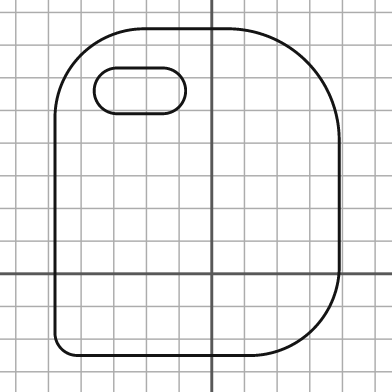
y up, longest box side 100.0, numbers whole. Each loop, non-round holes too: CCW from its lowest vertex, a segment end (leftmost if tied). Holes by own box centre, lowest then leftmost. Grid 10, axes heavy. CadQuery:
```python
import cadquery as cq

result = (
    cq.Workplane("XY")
    .moveTo(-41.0, -25.0)
    .lineTo(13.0, -25.0)
    .threePointArc((31.0, -17.0), (39.0, 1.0))
    .lineTo(39.0, 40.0)
    .threePointArc((29.0, 65.0), (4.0, 75.0))
    .lineTo(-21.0, 75.0)
    .threePointArc((-40.0, 67.0), (-48.0, 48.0))
    .lineTo(-48.0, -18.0)
    .threePointArc((-46.0, -23.0), (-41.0, -25.0))
    .close()
    .moveTo(-29.0, 49.0)
    .lineTo(-15.0, 49.0)
    .threePointArc((-8.0, 56.0), (-15.0, 63.0))
    .lineTo(-29.0, 63.0)
    .threePointArc((-36.0, 56.0), (-29.0, 49.0))
    .close()
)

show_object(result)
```